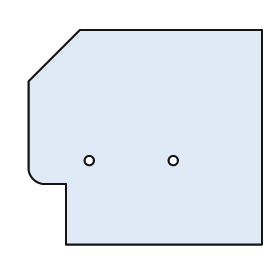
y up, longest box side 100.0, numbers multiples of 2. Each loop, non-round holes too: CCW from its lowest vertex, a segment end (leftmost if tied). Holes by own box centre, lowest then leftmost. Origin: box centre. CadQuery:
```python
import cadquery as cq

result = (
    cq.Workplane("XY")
    .moveTo(-34.0, -46.0)
    .lineTo(50.0, -46.0)
    .lineTo(50.0, 46.0)
    .lineTo(-28.0, 46.0)
    .lineTo(-50.0, 24.0)
    .lineTo(-50.0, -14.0)
    .threePointArc((-48.0, -18.0), (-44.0, -20.0))
    .lineTo(-34.0, -20.0)
    .close()
    .moveTo(-24.0, -10.0)
    .circle(2.0)
    .moveTo(12.0, -10.0)
    .circle(2.0)
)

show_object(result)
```